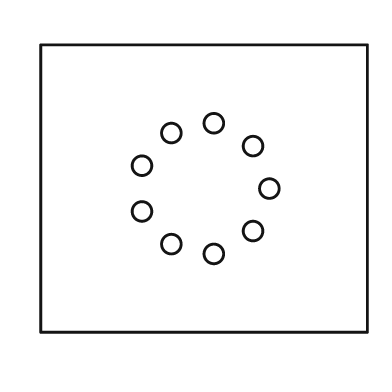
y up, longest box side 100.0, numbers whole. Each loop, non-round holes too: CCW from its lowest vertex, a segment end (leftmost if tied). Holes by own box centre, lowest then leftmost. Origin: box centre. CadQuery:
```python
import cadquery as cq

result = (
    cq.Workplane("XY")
    .moveTo(-50.0, -44.0)
    .lineTo(50.0, -44.0)
    .lineTo(50.0, 44.0)
    .lineTo(-50.0, 44.0)
    .close()
    .moveTo(3.0, -20.0)
    .circle(3.0)
    .moveTo(-10.0, -17.0)
    .circle(3.0)
    .moveTo(15.0, -13.0)
    .circle(3.0)
    .moveTo(-19.0, -7.0)
    .circle(3.0)
    .moveTo(20.0, 0.0)
    .circle(3.0)
    .moveTo(-19.0, 7.0)
    .circle(3.0)
    .moveTo(15.0, 13.0)
    .circle(3.0)
    .moveTo(-10.0, 17.0)
    .circle(3.0)
    .moveTo(3.0, 20.0)
    .circle(3.0)
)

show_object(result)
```